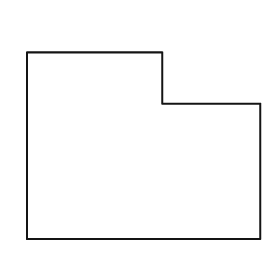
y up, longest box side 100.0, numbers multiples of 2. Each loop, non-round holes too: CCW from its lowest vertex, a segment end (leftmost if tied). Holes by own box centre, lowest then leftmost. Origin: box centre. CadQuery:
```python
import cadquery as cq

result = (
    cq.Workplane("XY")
    .moveTo(-50.0, -40.0)
    .lineTo(50.0, -40.0)
    .lineTo(50.0, 18.0)
    .lineTo(8.0, 18.0)
    .lineTo(8.0, 40.0)
    .lineTo(-50.0, 40.0)
    .close()
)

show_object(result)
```